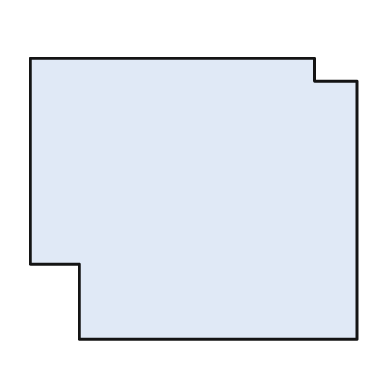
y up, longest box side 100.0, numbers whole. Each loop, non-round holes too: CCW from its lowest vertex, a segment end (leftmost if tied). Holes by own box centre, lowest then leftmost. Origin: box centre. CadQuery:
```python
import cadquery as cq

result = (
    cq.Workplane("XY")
    .moveTo(-35.0, -43.0)
    .lineTo(50.0, -43.0)
    .lineTo(50.0, 36.0)
    .lineTo(37.0, 36.0)
    .lineTo(37.0, 43.0)
    .lineTo(-50.0, 43.0)
    .lineTo(-50.0, -20.0)
    .lineTo(-35.0, -20.0)
    .close()
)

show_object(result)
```